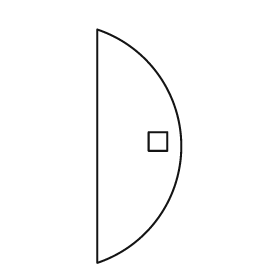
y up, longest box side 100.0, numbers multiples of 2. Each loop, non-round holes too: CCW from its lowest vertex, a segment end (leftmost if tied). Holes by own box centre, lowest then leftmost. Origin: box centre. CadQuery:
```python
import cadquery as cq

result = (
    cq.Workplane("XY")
    .moveTo(-18.0, -50.0)
    .threePointArc((18.0, 0.0), (-18.0, 50.0))
    .close()
    .moveTo(4.0, -2.0)
    .lineTo(12.0, -2.0)
    .lineTo(12.0, 6.0)
    .lineTo(4.0, 6.0)
    .close()
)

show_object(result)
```